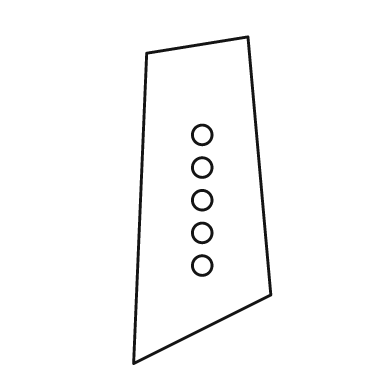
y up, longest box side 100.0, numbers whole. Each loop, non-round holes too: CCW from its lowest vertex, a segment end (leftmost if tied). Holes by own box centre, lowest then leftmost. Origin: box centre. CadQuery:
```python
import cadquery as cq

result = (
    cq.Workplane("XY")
    .moveTo(-21.0, -50.0)
    .lineTo(21.0, -29.0)
    .lineTo(14.0, 50.0)
    .lineTo(-17.0, 45.0)
    .close()
    .moveTo(0.0, -20.0)
    .circle(3.0)
    .moveTo(0.0, -10.0)
    .circle(3.0)
    .moveTo(0.0, 0.0)
    .circle(3.0)
    .moveTo(0.0, 10.0)
    .circle(3.0)
    .moveTo(0.0, 20.0)
    .circle(3.0)
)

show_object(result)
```